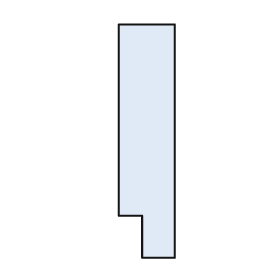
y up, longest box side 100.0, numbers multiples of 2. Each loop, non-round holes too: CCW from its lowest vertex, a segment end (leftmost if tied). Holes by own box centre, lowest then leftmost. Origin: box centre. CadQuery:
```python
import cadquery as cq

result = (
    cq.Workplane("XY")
    .moveTo(-2.0, -50.0)
    .lineTo(12.0, -50.0)
    .lineTo(12.0, 50.0)
    .lineTo(-12.0, 50.0)
    .lineTo(-12.0, -32.0)
    .lineTo(-2.0, -32.0)
    .close()
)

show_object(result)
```